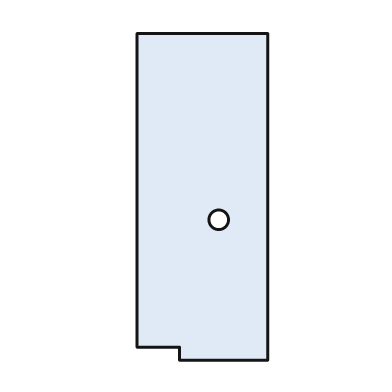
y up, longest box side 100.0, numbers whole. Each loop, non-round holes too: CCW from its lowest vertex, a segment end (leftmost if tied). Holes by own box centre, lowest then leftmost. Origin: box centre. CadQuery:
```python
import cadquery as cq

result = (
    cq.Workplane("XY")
    .moveTo(-7.0, -50.0)
    .lineTo(20.0, -50.0)
    .lineTo(20.0, 50.0)
    .lineTo(-20.0, 50.0)
    .lineTo(-20.0, -46.0)
    .lineTo(-7.0, -46.0)
    .close()
    .moveTo(5.0, -7.0)
    .circle(3.0)
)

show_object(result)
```